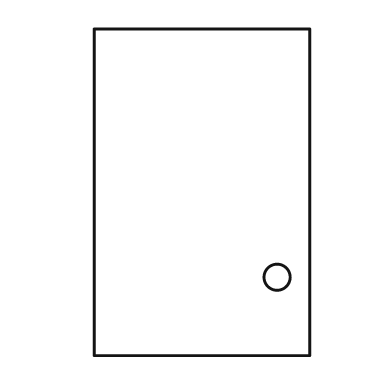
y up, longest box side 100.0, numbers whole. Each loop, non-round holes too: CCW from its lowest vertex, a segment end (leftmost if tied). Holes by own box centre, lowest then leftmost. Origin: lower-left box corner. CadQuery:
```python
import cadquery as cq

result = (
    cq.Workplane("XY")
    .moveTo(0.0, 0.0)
    .lineTo(66.0, 0.0)
    .lineTo(66.0, 100.0)
    .lineTo(0.0, 100.0)
    .close()
    .moveTo(56.0, 24.0)
    .circle(4.0)
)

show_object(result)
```